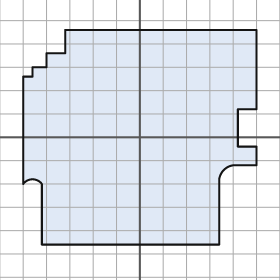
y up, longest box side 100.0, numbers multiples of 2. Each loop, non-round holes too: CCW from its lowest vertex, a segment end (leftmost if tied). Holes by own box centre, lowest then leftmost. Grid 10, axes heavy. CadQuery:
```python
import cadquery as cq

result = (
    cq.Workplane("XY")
    .moveTo(-42.0, -46.0)
    .lineTo(34.0, -46.0)
    .lineTo(34.0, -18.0)
    .threePointArc((36.0, -14.0), (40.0, -12.0))
    .lineTo(50.0, -12.0)
    .lineTo(50.0, -4.0)
    .lineTo(42.0, -4.0)
    .lineTo(42.0, 12.0)
    .lineTo(50.0, 12.0)
    .lineTo(50.0, 46.0)
    .lineTo(-32.0, 46.0)
    .lineTo(-32.0, 36.0)
    .lineTo(-40.0, 36.0)
    .lineTo(-40.0, 30.0)
    .lineTo(-46.0, 30.0)
    .lineTo(-46.0, 26.0)
    .lineTo(-50.0, 26.0)
    .lineTo(-50.0, -20.0)
    .threePointArc((-46.0, -18.0), (-42.0, -20.0))
    .close()
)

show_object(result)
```